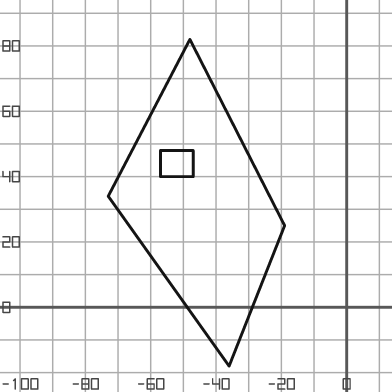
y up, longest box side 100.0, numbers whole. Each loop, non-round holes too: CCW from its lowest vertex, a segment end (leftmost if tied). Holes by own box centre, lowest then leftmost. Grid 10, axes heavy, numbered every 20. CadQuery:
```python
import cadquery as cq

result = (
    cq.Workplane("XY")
    .moveTo(-36.0, -18.0)
    .lineTo(-19.0, 25.0)
    .lineTo(-48.0, 82.0)
    .lineTo(-73.0, 34.0)
    .close()
    .moveTo(-57.0, 40.0)
    .lineTo(-47.0, 40.0)
    .lineTo(-47.0, 48.0)
    .lineTo(-57.0, 48.0)
    .close()
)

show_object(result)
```